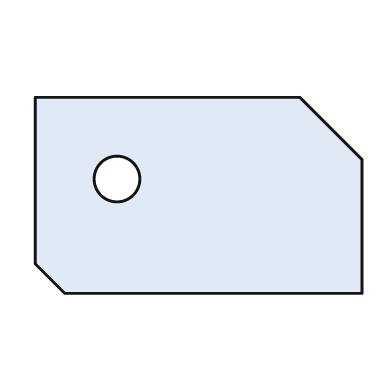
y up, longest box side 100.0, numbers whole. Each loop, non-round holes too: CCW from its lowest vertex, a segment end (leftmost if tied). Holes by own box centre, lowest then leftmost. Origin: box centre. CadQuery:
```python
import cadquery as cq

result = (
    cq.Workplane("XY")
    .moveTo(-41.0, -30.0)
    .lineTo(50.0, -30.0)
    .lineTo(50.0, 11.0)
    .lineTo(31.0, 30.0)
    .lineTo(-50.0, 30.0)
    .lineTo(-50.0, -21.0)
    .close()
    .moveTo(-25.0, 5.0)
    .circle(7.0)
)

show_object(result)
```